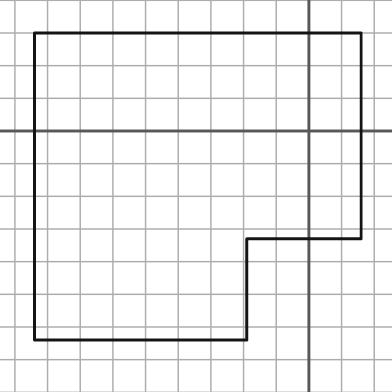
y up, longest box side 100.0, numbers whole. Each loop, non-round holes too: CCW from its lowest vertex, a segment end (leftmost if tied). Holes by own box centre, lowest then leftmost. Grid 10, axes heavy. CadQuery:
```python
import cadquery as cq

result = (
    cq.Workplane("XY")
    .moveTo(-84.0, -64.0)
    .lineTo(-19.0, -64.0)
    .lineTo(-19.0, -33.0)
    .lineTo(16.0, -33.0)
    .lineTo(16.0, 30.0)
    .lineTo(-84.0, 30.0)
    .close()
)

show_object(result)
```